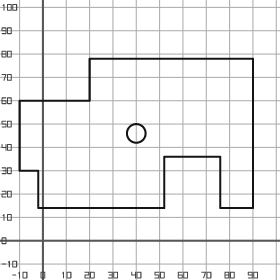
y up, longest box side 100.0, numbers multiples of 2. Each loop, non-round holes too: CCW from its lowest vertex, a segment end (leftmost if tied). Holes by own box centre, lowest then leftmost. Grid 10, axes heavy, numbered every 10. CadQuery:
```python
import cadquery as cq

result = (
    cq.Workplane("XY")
    .moveTo(-2.0, 14.0)
    .lineTo(52.0, 14.0)
    .lineTo(52.0, 36.0)
    .lineTo(76.0, 36.0)
    .lineTo(76.0, 14.0)
    .lineTo(90.0, 14.0)
    .lineTo(90.0, 78.0)
    .lineTo(20.0, 78.0)
    .lineTo(20.0, 60.0)
    .lineTo(-10.0, 60.0)
    .lineTo(-10.0, 30.0)
    .lineTo(-2.0, 30.0)
    .close()
    .moveTo(40.0, 46.0)
    .circle(4.0)
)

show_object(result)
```